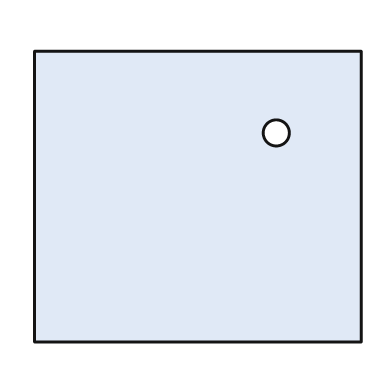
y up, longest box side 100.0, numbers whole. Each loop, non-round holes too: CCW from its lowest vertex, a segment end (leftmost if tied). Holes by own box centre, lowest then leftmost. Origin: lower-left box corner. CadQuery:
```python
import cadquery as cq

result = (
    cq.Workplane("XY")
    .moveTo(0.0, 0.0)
    .lineTo(100.0, 0.0)
    .lineTo(100.0, 89.0)
    .lineTo(0.0, 89.0)
    .close()
    .moveTo(74.0, 64.0)
    .circle(4.0)
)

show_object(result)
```